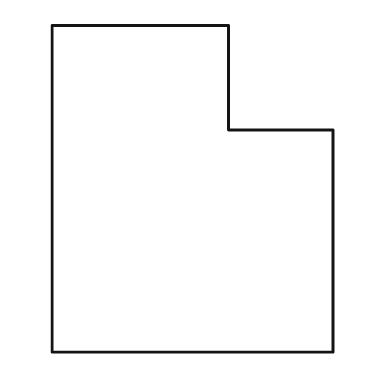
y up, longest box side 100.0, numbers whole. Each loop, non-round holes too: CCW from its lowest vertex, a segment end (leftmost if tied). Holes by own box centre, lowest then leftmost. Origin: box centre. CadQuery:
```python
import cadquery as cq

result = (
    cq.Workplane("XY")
    .moveTo(-43.0, -50.0)
    .lineTo(43.0, -50.0)
    .lineTo(43.0, 18.0)
    .lineTo(11.0, 18.0)
    .lineTo(11.0, 50.0)
    .lineTo(-43.0, 50.0)
    .close()
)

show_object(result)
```